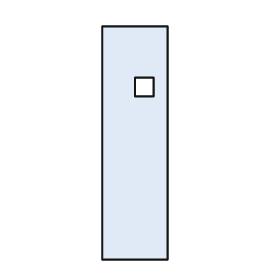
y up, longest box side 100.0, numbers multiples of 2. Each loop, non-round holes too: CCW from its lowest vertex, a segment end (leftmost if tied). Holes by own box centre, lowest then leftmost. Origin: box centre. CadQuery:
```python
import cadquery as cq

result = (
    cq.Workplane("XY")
    .moveTo(-14.0, -50.0)
    .lineTo(14.0, -50.0)
    .lineTo(14.0, 50.0)
    .lineTo(-14.0, 50.0)
    .close()
    .moveTo(0.0, 20.0)
    .lineTo(8.0, 20.0)
    .lineTo(8.0, 28.0)
    .lineTo(0.0, 28.0)
    .close()
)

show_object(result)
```